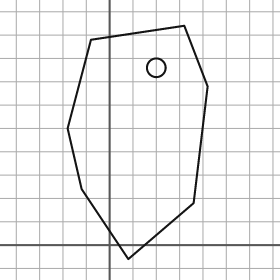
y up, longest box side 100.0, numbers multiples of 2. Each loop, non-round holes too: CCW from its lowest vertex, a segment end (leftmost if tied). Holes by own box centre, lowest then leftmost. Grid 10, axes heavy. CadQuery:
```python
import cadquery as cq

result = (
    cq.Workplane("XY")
    .moveTo(8.0, -6.0)
    .lineTo(36.0, 18.0)
    .lineTo(42.0, 68.0)
    .lineTo(32.0, 94.0)
    .lineTo(-8.0, 88.0)
    .lineTo(-18.0, 50.0)
    .lineTo(-12.0, 24.0)
    .close()
    .moveTo(20.0, 76.0)
    .circle(4.0)
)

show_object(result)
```